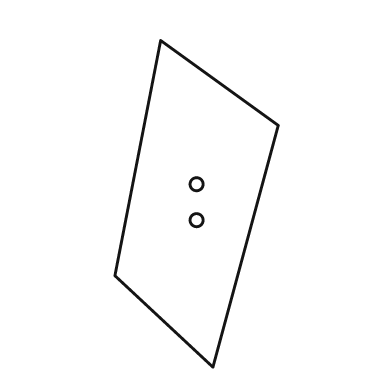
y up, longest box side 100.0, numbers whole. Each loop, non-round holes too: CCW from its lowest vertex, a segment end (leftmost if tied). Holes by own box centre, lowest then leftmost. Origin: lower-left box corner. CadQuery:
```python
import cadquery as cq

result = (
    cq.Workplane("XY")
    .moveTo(30.0, 0.0)
    .lineTo(50.0, 74.0)
    .lineTo(14.0, 100.0)
    .lineTo(0.0, 28.0)
    .close()
    .moveTo(25.0, 45.0)
    .circle(2.0)
    .moveTo(25.0, 56.0)
    .circle(2.0)
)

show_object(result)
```